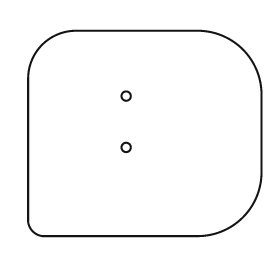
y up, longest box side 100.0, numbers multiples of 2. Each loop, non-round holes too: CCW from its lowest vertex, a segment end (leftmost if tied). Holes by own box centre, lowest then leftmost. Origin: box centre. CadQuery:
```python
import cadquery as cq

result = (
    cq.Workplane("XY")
    .moveTo(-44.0, -44.0)
    .lineTo(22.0, -44.0)
    .threePointArc((42.0, -36.0), (50.0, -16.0))
    .lineTo(50.0, 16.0)
    .threePointArc((42.0, 36.0), (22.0, 44.0))
    .lineTo(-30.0, 44.0)
    .threePointArc((-44.0, 38.0), (-50.0, 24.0))
    .lineTo(-50.0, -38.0)
    .threePointArc((-48.0, -42.0), (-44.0, -44.0))
    .close()
    .moveTo(-8.0, -6.0)
    .circle(2.0)
    .moveTo(-8.0, 16.0)
    .circle(2.0)
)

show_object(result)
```